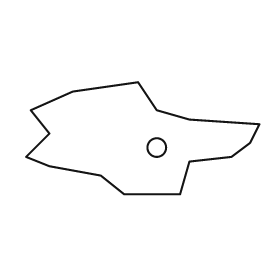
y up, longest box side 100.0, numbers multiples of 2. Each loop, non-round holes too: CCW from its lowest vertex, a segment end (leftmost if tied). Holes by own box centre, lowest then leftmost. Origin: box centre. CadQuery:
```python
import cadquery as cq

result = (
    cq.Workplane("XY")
    .moveTo(-8.0, -24.0)
    .lineTo(16.0, -24.0)
    .lineTo(20.0, -10.0)
    .lineTo(38.0, -8.0)
    .lineTo(46.0, -2.0)
    .lineTo(50.0, 6.0)
    .lineTo(20.0, 8.0)
    .lineTo(6.0, 12.0)
    .lineTo(-2.0, 24.0)
    .lineTo(-30.0, 20.0)
    .lineTo(-48.0, 12.0)
    .lineTo(-40.0, 2.0)
    .lineTo(-50.0, -8.0)
    .lineTo(-40.0, -12.0)
    .lineTo(-18.0, -16.0)
    .close()
    .moveTo(6.0, -4.0)
    .circle(4.0)
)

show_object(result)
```